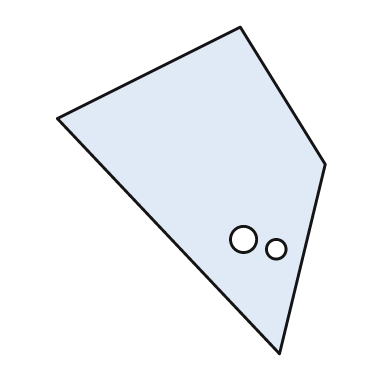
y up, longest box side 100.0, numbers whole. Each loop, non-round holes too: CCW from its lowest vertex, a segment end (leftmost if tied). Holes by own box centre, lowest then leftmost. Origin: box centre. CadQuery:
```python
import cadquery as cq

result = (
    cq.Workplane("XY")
    .moveTo(27.0, -50.0)
    .lineTo(41.0, 8.0)
    .lineTo(15.0, 50.0)
    .lineTo(-41.0, 22.0)
    .close()
    .moveTo(26.0, -18.0)
    .circle(3.0)
    .moveTo(16.0, -15.0)
    .circle(4.0)
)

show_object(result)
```